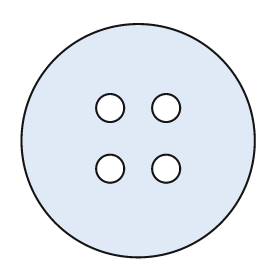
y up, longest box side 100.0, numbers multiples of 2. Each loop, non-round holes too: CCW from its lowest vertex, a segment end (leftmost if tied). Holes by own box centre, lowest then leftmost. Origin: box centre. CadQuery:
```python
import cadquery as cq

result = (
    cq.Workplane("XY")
    .moveTo(0.0, 0.0)
    .circle(50.0)
    .moveTo(-12.0, -12.0)
    .circle(6.0)
    .moveTo(12.0, -12.0)
    .circle(6.0)
    .moveTo(-12.0, 14.0)
    .circle(6.0)
    .moveTo(12.0, 14.0)
    .circle(6.0)
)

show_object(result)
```